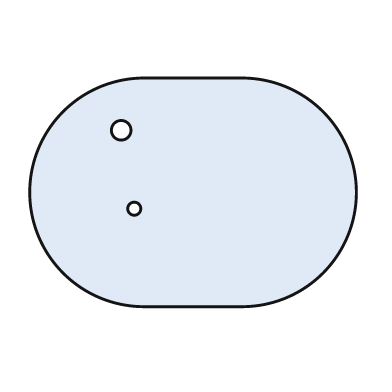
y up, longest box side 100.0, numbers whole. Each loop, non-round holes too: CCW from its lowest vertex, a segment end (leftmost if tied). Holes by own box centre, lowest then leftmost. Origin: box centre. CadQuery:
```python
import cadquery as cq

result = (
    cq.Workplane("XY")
    .moveTo(-15.0, -35.0)
    .lineTo(15.0, -35.0)
    .threePointArc((50.0, 0.0), (15.0, 35.0))
    .lineTo(-15.0, 35.0)
    .threePointArc((-50.0, 0.0), (-15.0, -35.0))
    .close()
    .moveTo(-18.0, -5.0)
    .circle(2.0)
    .moveTo(-22.0, 19.0)
    .circle(3.0)
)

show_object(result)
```